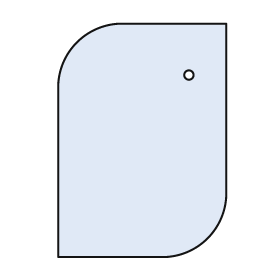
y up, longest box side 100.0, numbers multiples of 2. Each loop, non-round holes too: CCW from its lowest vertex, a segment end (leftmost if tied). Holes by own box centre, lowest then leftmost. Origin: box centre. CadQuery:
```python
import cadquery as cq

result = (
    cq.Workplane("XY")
    .moveTo(-36.0, -50.0)
    .lineTo(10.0, -50.0)
    .threePointArc((28.0, -42.0), (36.0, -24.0))
    .lineTo(36.0, 50.0)
    .lineTo(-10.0, 50.0)
    .threePointArc((-28.0, 42.0), (-36.0, 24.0))
    .close()
    .moveTo(20.0, 28.0)
    .circle(2.0)
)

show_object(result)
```